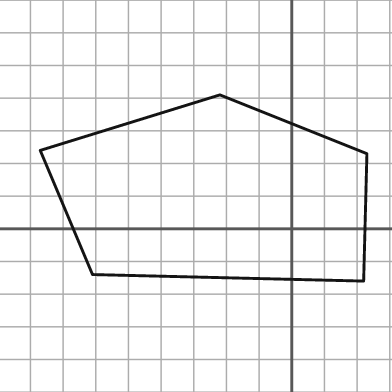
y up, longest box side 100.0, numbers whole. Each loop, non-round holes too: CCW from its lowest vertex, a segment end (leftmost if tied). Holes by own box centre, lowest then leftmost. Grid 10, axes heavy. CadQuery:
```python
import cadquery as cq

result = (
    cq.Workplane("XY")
    .moveTo(22.0, -16.0)
    .lineTo(23.0, 23.0)
    .lineTo(-22.0, 41.0)
    .lineTo(-77.0, 24.0)
    .lineTo(-61.0, -14.0)
    .close()
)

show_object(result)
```